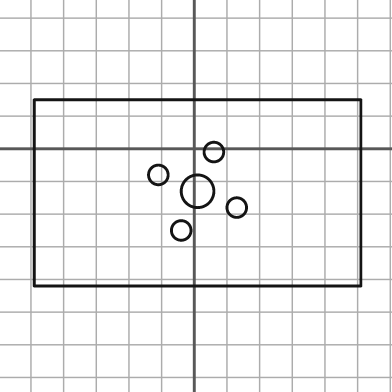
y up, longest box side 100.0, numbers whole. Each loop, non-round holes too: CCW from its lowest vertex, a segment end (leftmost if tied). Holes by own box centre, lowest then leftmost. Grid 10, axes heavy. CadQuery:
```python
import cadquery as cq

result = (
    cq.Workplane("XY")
    .moveTo(-49.0, -42.0)
    .lineTo(51.0, -42.0)
    .lineTo(51.0, 15.0)
    .lineTo(-49.0, 15.0)
    .close()
    .moveTo(-4.0, -25.0)
    .circle(3.0)
    .moveTo(13.0, -18.0)
    .circle(3.0)
    .moveTo(1.0, -13.0)
    .circle(5.0)
    .moveTo(-11.0, -8.0)
    .circle(3.0)
    .moveTo(6.0, -1.0)
    .circle(3.0)
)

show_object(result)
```